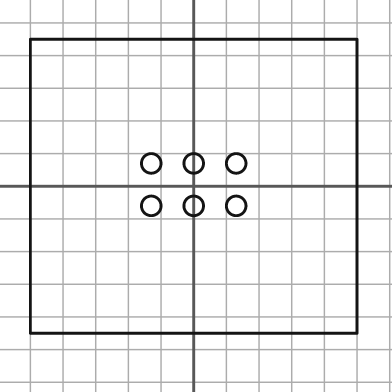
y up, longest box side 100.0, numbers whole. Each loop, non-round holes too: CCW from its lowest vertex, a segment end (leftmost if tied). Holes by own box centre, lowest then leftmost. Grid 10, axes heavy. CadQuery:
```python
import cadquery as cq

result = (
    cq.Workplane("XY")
    .moveTo(-50.0, -45.0)
    .lineTo(50.0, -45.0)
    .lineTo(50.0, 45.0)
    .lineTo(-50.0, 45.0)
    .close()
    .moveTo(-13.0, -6.0)
    .circle(3.0)
    .moveTo(0.0, -6.0)
    .circle(3.0)
    .moveTo(13.0, -6.0)
    .circle(3.0)
    .moveTo(-13.0, 7.0)
    .circle(3.0)
    .moveTo(0.0, 7.0)
    .circle(3.0)
    .moveTo(13.0, 7.0)
    .circle(3.0)
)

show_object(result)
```